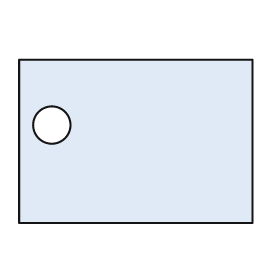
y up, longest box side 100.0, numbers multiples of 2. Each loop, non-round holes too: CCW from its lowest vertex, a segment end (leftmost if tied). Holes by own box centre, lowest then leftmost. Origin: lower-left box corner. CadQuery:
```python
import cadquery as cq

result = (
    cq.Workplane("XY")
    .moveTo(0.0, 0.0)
    .lineTo(100.0, 0.0)
    .lineTo(100.0, 70.0)
    .lineTo(0.0, 70.0)
    .close()
    .moveTo(14.0, 42.0)
    .circle(8.0)
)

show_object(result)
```